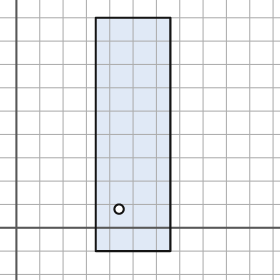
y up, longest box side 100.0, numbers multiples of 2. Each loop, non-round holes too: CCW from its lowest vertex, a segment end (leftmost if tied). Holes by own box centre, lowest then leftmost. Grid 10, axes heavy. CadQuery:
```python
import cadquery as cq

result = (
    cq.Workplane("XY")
    .moveTo(34.0, -10.0)
    .lineTo(66.0, -10.0)
    .lineTo(66.0, 90.0)
    .lineTo(34.0, 90.0)
    .close()
    .moveTo(44.0, 8.0)
    .circle(2.0)
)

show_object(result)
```